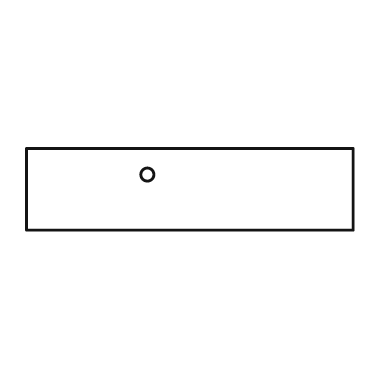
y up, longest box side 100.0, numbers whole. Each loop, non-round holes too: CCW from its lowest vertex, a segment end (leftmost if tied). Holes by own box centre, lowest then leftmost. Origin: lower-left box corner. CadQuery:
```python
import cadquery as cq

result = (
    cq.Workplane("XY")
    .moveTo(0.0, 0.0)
    .lineTo(100.0, 0.0)
    .lineTo(100.0, 25.0)
    .lineTo(0.0, 25.0)
    .close()
    .moveTo(37.0, 17.0)
    .circle(2.0)
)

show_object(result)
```